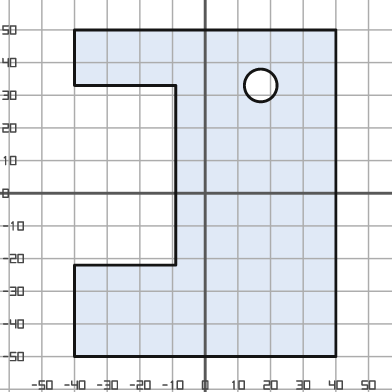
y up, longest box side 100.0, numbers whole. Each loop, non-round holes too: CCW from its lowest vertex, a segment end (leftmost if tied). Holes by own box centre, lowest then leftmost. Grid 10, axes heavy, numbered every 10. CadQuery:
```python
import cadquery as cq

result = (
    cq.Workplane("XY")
    .moveTo(-40.0, -50.0)
    .lineTo(40.0, -50.0)
    .lineTo(40.0, 50.0)
    .lineTo(-40.0, 50.0)
    .lineTo(-40.0, 33.0)
    .lineTo(-9.0, 33.0)
    .lineTo(-9.0, -22.0)
    .lineTo(-40.0, -22.0)
    .close()
    .moveTo(17.0, 33.0)
    .circle(5.0)
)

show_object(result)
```